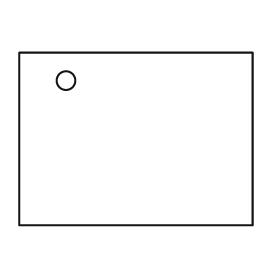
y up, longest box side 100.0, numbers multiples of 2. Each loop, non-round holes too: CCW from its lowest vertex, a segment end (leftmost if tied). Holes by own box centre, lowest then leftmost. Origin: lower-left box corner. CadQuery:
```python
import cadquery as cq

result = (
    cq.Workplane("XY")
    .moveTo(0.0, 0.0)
    .lineTo(100.0, 0.0)
    .lineTo(100.0, 74.0)
    .lineTo(0.0, 74.0)
    .close()
    .moveTo(20.0, 62.0)
    .circle(4.0)
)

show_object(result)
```